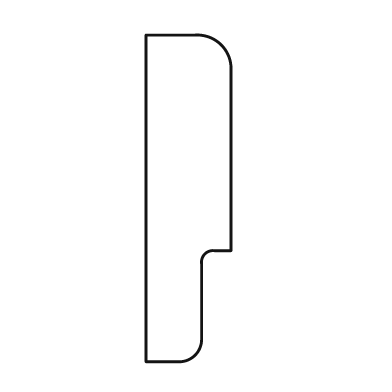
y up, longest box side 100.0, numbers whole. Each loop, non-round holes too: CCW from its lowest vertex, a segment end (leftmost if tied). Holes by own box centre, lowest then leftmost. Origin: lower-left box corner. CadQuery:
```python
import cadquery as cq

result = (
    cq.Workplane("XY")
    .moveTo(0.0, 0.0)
    .lineTo(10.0, 0.0)
    .threePointArc((15.0, 2.0), (17.0, 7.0))
    .lineTo(17.0, 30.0)
    .threePointArc((18.0, 33.0), (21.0, 34.0))
    .lineTo(26.0, 34.0)
    .lineTo(26.0, 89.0)
    .threePointArc((23.0, 97.0), (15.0, 100.0))
    .lineTo(0.0, 100.0)
    .close()
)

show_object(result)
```